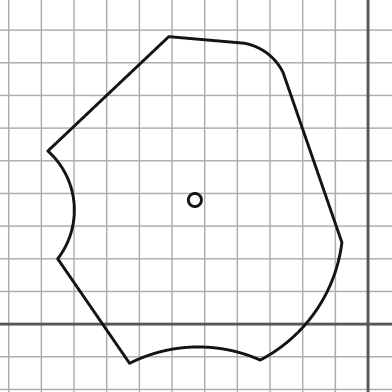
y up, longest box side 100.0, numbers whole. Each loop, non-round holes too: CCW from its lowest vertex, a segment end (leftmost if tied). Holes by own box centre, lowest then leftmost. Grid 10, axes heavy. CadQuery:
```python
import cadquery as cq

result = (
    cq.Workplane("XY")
    .moveTo(-73.0, -12.0)
    .threePointArc((-53.0, -7.0), (-33.0, -11.0))
    .threePointArc((-16.0, 4.0), (-8.0, 25.0))
    .lineTo(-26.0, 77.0)
    .threePointArc((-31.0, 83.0), (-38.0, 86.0))
    .lineTo(-61.0, 88.0)
    .lineTo(-98.0, 53.0)
    .threePointArc((-90.0, 37.0), (-95.0, 20.0))
    .close()
    .moveTo(-53.0, 38.0)
    .circle(2.0)
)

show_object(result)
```